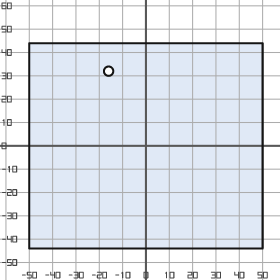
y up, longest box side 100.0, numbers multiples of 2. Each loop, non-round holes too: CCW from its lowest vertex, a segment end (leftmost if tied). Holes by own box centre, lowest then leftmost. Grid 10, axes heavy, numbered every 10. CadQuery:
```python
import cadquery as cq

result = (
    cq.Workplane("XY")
    .moveTo(-50.0, -44.0)
    .lineTo(50.0, -44.0)
    .lineTo(50.0, 44.0)
    .lineTo(-50.0, 44.0)
    .close()
    .moveTo(-16.0, 32.0)
    .circle(2.0)
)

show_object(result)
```